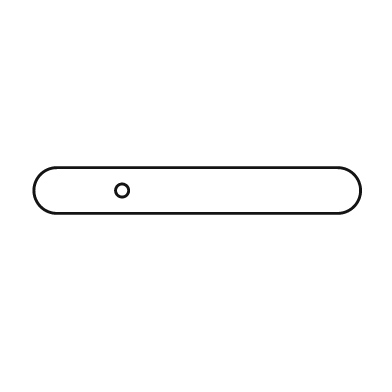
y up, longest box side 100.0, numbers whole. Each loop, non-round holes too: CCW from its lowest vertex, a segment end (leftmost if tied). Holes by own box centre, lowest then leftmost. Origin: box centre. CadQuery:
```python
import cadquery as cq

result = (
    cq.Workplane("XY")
    .moveTo(-43.0, -7.0)
    .lineTo(43.0, -7.0)
    .threePointArc((50.0, 0.0), (43.0, 7.0))
    .lineTo(-43.0, 7.0)
    .threePointArc((-50.0, 0.0), (-43.0, -7.0))
    .close()
    .moveTo(-23.0, 0.0)
    .circle(2.0)
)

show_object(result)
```